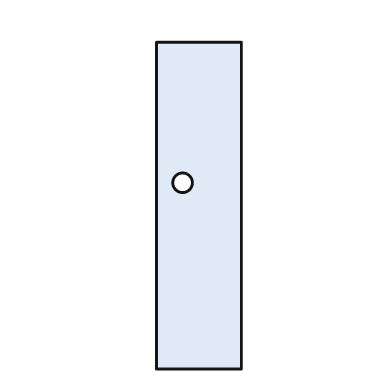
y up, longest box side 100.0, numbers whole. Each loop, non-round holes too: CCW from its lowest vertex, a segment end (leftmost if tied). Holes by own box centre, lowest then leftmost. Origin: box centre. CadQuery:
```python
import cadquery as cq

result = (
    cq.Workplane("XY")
    .moveTo(-13.0, -50.0)
    .lineTo(13.0, -50.0)
    .lineTo(13.0, 50.0)
    .lineTo(-13.0, 50.0)
    .close()
    .moveTo(-5.0, 7.0)
    .circle(3.0)
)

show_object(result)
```